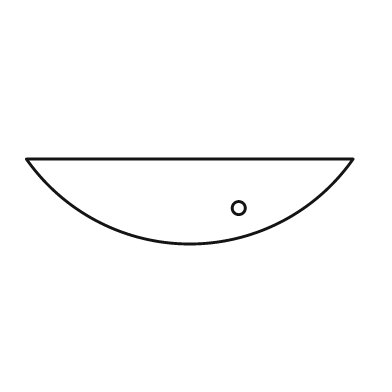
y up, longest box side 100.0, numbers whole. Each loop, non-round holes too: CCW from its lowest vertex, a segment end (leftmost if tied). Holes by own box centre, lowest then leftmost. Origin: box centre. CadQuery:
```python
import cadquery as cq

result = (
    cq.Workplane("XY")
    .moveTo(-50.0, 13.0)
    .threePointArc((0.0, -13.0), (50.0, 13.0))
    .close()
    .moveTo(15.0, -2.0)
    .circle(2.0)
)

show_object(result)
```